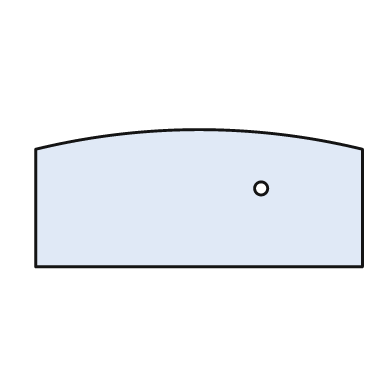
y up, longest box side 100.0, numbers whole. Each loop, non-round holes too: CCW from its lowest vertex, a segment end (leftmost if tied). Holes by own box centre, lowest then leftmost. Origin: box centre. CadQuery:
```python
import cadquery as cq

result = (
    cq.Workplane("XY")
    .moveTo(-50.0, -21.0)
    .lineTo(50.0, -21.0)
    .lineTo(50.0, 15.0)
    .threePointArc((0.0, 21.0), (-50.0, 15.0))
    .close()
    .moveTo(19.0, 3.0)
    .circle(2.0)
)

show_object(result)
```